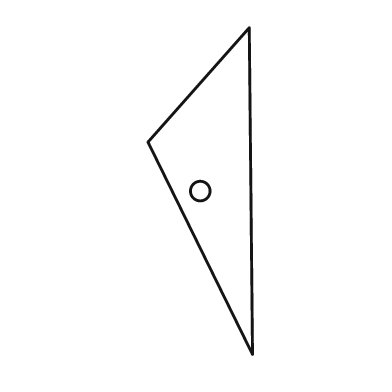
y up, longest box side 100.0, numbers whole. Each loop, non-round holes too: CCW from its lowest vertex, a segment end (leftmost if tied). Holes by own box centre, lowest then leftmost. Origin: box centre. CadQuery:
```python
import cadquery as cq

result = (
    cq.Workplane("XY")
    .moveTo(16.0, -50.0)
    .lineTo(15.0, 50.0)
    .lineTo(-16.0, 15.0)
    .close()
    .moveTo(0.0, 0.0)
    .circle(3.0)
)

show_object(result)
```